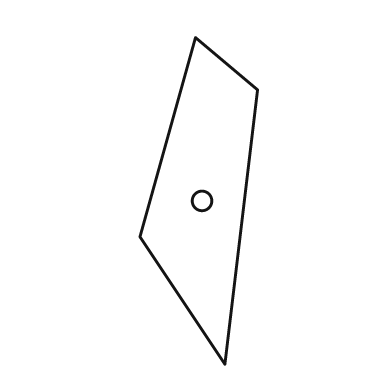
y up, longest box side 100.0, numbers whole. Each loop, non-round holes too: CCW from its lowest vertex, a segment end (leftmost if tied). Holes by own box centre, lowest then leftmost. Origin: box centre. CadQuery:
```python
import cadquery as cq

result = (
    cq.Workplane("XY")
    .moveTo(8.0, -50.0)
    .lineTo(18.0, 34.0)
    .lineTo(-1.0, 50.0)
    .lineTo(-18.0, -11.0)
    .close()
    .moveTo(1.0, 0.0)
    .circle(3.0)
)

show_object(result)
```